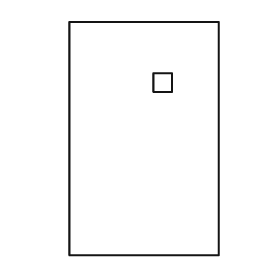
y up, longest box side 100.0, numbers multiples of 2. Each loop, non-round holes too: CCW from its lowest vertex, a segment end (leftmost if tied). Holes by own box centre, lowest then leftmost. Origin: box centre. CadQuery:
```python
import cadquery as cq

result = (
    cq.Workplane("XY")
    .moveTo(-32.0, -50.0)
    .lineTo(32.0, -50.0)
    .lineTo(32.0, 50.0)
    .lineTo(-32.0, 50.0)
    .close()
    .moveTo(4.0, 20.0)
    .lineTo(12.0, 20.0)
    .lineTo(12.0, 28.0)
    .lineTo(4.0, 28.0)
    .close()
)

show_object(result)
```